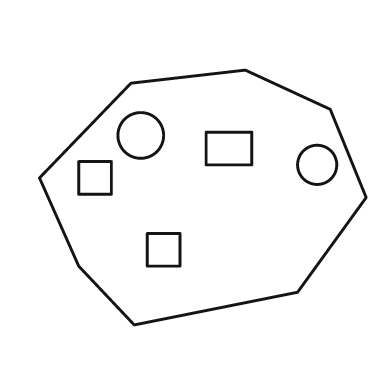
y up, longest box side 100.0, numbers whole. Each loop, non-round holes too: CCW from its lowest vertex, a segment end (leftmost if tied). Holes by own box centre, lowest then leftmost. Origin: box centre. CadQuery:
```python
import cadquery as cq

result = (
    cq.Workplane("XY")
    .moveTo(-21.0, -39.0)
    .lineTo(29.0, -29.0)
    .lineTo(50.0, 0.0)
    .lineTo(39.0, 27.0)
    .lineTo(13.0, 39.0)
    .lineTo(-22.0, 35.0)
    .lineTo(-50.0, 6.0)
    .lineTo(-38.0, -21.0)
    .close()
    .moveTo(-17.0, -21.0)
    .lineTo(-7.0, -21.0)
    .lineTo(-7.0, -11.0)
    .lineTo(-17.0, -11.0)
    .close()
    .moveTo(-38.0, 1.0)
    .lineTo(-28.0, 1.0)
    .lineTo(-28.0, 11.0)
    .lineTo(-38.0, 11.0)
    .close()
    .moveTo(35.0, 10.0)
    .circle(6.0)
    .moveTo(1.0, 10.0)
    .lineTo(15.0, 10.0)
    .lineTo(15.0, 20.0)
    .lineTo(1.0, 20.0)
    .close()
    .moveTo(-19.0, 19.0)
    .circle(7.0)
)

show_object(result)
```